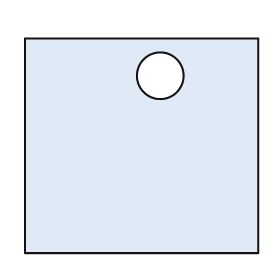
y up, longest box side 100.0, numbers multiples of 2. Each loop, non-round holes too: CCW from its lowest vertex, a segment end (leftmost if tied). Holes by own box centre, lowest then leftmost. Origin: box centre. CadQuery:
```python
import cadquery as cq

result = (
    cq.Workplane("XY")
    .moveTo(-50.0, -46.0)
    .lineTo(50.0, -46.0)
    .lineTo(50.0, 46.0)
    .lineTo(-50.0, 46.0)
    .close()
    .moveTo(8.0, 30.0)
    .circle(10.0)
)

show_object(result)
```